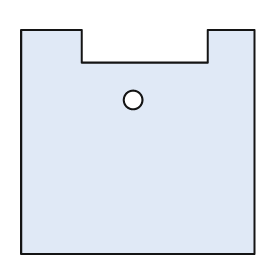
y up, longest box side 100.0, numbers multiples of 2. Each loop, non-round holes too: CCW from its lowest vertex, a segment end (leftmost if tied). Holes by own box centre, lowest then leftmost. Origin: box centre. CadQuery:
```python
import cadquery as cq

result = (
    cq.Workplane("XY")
    .moveTo(-50.0, -48.0)
    .lineTo(50.0, -48.0)
    .lineTo(50.0, 48.0)
    .lineTo(30.0, 48.0)
    .lineTo(30.0, 34.0)
    .lineTo(-24.0, 34.0)
    .lineTo(-24.0, 48.0)
    .lineTo(-50.0, 48.0)
    .close()
    .moveTo(-2.0, 18.0)
    .circle(4.0)
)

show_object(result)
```